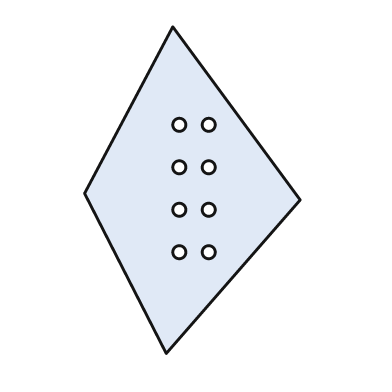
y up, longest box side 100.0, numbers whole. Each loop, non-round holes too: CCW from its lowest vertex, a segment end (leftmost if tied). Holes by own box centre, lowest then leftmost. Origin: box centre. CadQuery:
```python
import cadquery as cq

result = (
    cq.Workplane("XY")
    .moveTo(-8.0, -50.0)
    .lineTo(33.0, -3.0)
    .lineTo(-6.0, 50.0)
    .lineTo(-33.0, -1.0)
    .close()
    .moveTo(-4.0, -19.0)
    .circle(2.0)
    .moveTo(5.0, -19.0)
    .circle(2.0)
    .moveTo(-4.0, -6.0)
    .circle(2.0)
    .moveTo(5.0, -6.0)
    .circle(2.0)
    .moveTo(-4.0, 7.0)
    .circle(2.0)
    .moveTo(5.0, 7.0)
    .circle(2.0)
    .moveTo(-4.0, 20.0)
    .circle(2.0)
    .moveTo(5.0, 20.0)
    .circle(2.0)
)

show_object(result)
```